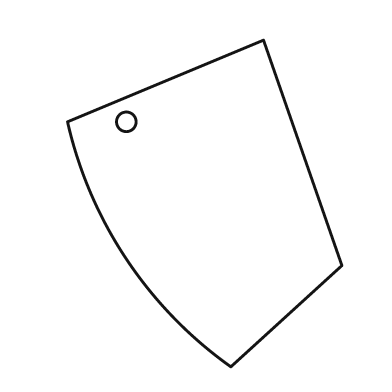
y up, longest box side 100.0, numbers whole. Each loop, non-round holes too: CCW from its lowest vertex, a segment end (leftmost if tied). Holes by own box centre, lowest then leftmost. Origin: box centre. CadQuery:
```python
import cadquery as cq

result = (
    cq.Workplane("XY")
    .moveTo(8.0, -50.0)
    .lineTo(42.0, -19.0)
    .lineTo(18.0, 50.0)
    .lineTo(-42.0, 25.0)
    .threePointArc((-24.0, -17.0), (8.0, -50.0))
    .close()
    .moveTo(-24.0, 25.0)
    .circle(3.0)
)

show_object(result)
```